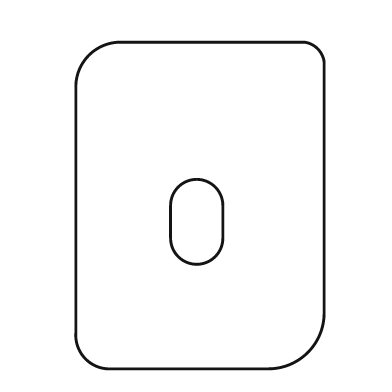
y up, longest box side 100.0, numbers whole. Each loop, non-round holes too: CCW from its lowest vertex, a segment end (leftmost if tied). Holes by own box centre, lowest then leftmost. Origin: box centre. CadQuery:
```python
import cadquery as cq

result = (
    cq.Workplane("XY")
    .moveTo(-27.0, -50.0)
    .lineTo(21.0, -50.0)
    .threePointArc((33.0, -45.0), (38.0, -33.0))
    .lineTo(38.0, 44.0)
    .threePointArc((36.0, 48.0), (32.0, 50.0))
    .lineTo(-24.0, 50.0)
    .threePointArc((-34.0, 46.0), (-38.0, 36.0))
    .lineTo(-38.0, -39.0)
    .threePointArc((-35.0, -47.0), (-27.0, -50.0))
    .close()
    .moveTo(-9.0, -10.0)
    .threePointArc((-1.0, -18.0), (7.0, -10.0))
    .lineTo(7.0, 0.0)
    .threePointArc((-1.0, 8.0), (-9.0, 0.0))
    .close()
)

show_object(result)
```